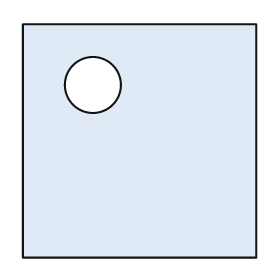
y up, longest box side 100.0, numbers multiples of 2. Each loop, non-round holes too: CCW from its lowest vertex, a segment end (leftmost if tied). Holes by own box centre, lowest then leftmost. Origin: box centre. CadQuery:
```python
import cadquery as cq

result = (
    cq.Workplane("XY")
    .moveTo(-50.0, -50.0)
    .lineTo(50.0, -50.0)
    .lineTo(50.0, 50.0)
    .lineTo(-50.0, 50.0)
    .close()
    .moveTo(-20.0, 24.0)
    .circle(12.0)
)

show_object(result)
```